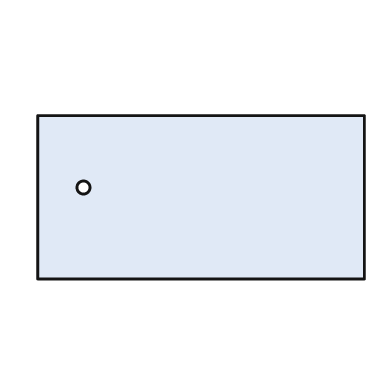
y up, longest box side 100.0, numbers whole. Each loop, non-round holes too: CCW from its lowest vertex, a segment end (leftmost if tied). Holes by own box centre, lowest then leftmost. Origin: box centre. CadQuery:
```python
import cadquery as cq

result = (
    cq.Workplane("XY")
    .moveTo(-50.0, -25.0)
    .lineTo(50.0, -25.0)
    .lineTo(50.0, 25.0)
    .lineTo(-50.0, 25.0)
    .close()
    .moveTo(-36.0, 3.0)
    .circle(2.0)
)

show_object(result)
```